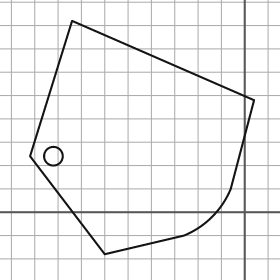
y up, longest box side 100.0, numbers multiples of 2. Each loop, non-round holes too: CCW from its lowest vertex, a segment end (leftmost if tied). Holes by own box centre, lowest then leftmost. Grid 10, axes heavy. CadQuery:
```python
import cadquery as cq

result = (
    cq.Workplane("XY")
    .moveTo(-60.0, -18.0)
    .lineTo(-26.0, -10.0)
    .threePointArc((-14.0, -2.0), (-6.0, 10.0))
    .lineTo(4.0, 48.0)
    .lineTo(-74.0, 82.0)
    .lineTo(-92.0, 24.0)
    .close()
    .moveTo(-82.0, 24.0)
    .circle(4.0)
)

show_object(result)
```